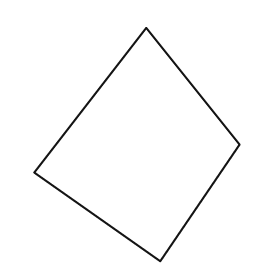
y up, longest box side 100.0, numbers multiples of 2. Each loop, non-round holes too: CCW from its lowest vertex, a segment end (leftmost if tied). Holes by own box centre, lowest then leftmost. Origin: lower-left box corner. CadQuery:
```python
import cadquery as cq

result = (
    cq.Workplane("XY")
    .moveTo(54.0, 0.0)
    .lineTo(88.0, 50.0)
    .lineTo(48.0, 100.0)
    .lineTo(0.0, 38.0)
    .close()
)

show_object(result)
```